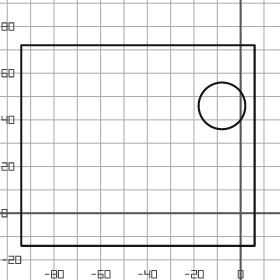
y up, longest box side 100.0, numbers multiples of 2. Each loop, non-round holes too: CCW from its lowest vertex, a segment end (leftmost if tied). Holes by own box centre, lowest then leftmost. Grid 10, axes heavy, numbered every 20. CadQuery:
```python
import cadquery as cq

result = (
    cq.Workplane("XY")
    .moveTo(-94.0, -14.0)
    .lineTo(6.0, -14.0)
    .lineTo(6.0, 72.0)
    .lineTo(-94.0, 72.0)
    .close()
    .moveTo(-8.0, 46.0)
    .circle(10.0)
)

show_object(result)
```